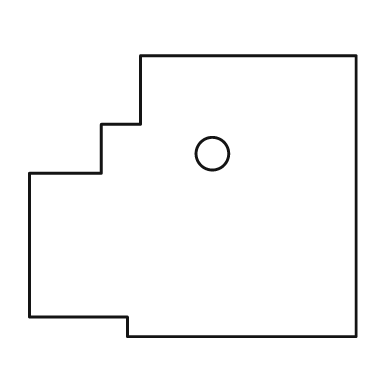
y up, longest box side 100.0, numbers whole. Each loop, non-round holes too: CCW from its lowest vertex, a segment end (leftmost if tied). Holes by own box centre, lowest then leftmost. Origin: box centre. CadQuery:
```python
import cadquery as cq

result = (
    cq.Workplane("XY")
    .moveTo(-20.0, -43.0)
    .lineTo(50.0, -43.0)
    .lineTo(50.0, 43.0)
    .lineTo(-16.0, 43.0)
    .lineTo(-16.0, 22.0)
    .lineTo(-28.0, 22.0)
    .lineTo(-28.0, 7.0)
    .lineTo(-50.0, 7.0)
    .lineTo(-50.0, -37.0)
    .lineTo(-20.0, -37.0)
    .close()
    .moveTo(6.0, 13.0)
    .circle(5.0)
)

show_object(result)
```